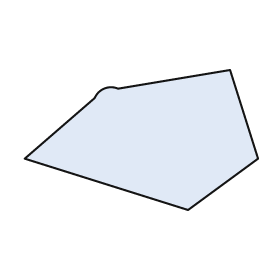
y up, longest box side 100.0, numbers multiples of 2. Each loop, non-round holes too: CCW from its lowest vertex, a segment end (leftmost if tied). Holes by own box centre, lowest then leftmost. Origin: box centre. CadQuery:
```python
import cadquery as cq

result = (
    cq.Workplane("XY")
    .moveTo(20.0, -30.0)
    .lineTo(50.0, -8.0)
    .lineTo(38.0, 30.0)
    .lineTo(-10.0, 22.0)
    .threePointArc((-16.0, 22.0), (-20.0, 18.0))
    .lineTo(-50.0, -8.0)
    .close()
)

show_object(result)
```